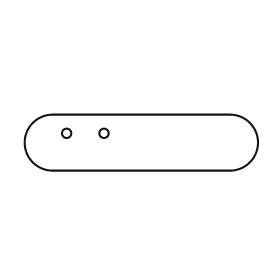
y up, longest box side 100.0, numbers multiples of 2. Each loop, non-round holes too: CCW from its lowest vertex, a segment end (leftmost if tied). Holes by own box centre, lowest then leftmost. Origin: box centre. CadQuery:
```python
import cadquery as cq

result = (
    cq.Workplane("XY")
    .moveTo(-38.0, -12.0)
    .lineTo(38.0, -12.0)
    .threePointArc((50.0, 0.0), (38.0, 12.0))
    .lineTo(-38.0, 12.0)
    .threePointArc((-50.0, 0.0), (-38.0, -12.0))
    .close()
    .moveTo(-32.0, 4.0)
    .circle(2.0)
    .moveTo(-16.0, 4.0)
    .circle(2.0)
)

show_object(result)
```